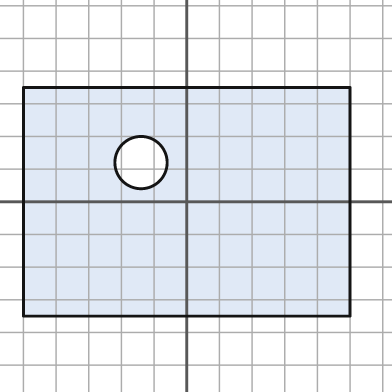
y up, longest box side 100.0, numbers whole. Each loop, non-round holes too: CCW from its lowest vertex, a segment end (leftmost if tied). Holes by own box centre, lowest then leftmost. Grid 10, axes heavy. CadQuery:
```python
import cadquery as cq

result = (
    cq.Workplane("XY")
    .moveTo(-50.0, -35.0)
    .lineTo(50.0, -35.0)
    .lineTo(50.0, 35.0)
    .lineTo(-50.0, 35.0)
    .close()
    .moveTo(-14.0, 12.0)
    .circle(8.0)
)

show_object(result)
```